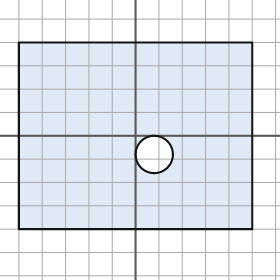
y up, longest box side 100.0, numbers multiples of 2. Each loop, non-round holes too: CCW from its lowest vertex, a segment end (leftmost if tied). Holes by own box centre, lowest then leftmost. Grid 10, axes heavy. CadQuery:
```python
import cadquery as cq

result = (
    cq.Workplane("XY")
    .moveTo(-50.0, -40.0)
    .lineTo(50.0, -40.0)
    .lineTo(50.0, 40.0)
    .lineTo(-50.0, 40.0)
    .close()
    .moveTo(8.0, -8.0)
    .circle(8.0)
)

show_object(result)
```